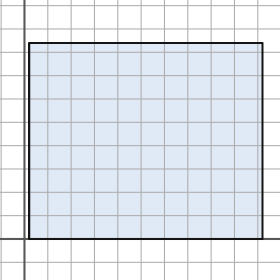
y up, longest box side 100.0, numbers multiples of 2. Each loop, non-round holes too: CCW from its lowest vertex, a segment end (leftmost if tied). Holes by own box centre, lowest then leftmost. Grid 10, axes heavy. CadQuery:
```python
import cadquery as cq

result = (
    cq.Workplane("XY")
    .moveTo(2.0, 0.0)
    .lineTo(102.0, 0.0)
    .lineTo(102.0, 84.0)
    .lineTo(2.0, 84.0)
    .close()
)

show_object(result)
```